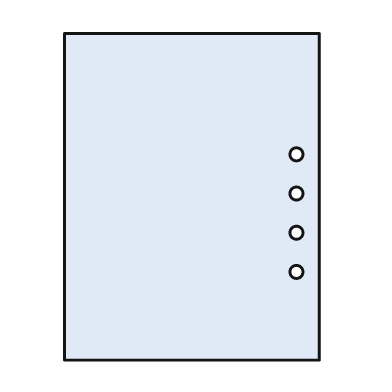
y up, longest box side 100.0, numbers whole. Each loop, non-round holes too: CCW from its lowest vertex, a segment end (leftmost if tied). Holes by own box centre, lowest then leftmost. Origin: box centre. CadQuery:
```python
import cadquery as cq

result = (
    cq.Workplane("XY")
    .moveTo(-39.0, -50.0)
    .lineTo(39.0, -50.0)
    .lineTo(39.0, 50.0)
    .lineTo(-39.0, 50.0)
    .close()
    .moveTo(32.0, -23.0)
    .circle(2.0)
    .moveTo(32.0, -11.0)
    .circle(2.0)
    .moveTo(32.0, 1.0)
    .circle(2.0)
    .moveTo(32.0, 13.0)
    .circle(2.0)
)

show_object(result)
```